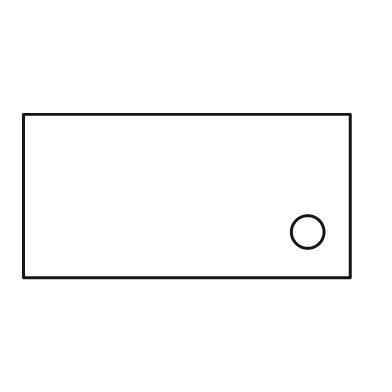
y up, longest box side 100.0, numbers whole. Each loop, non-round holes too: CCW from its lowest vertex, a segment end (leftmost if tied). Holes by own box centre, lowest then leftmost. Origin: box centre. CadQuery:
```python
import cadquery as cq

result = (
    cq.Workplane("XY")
    .moveTo(-50.0, -25.0)
    .lineTo(50.0, -25.0)
    .lineTo(50.0, 25.0)
    .lineTo(-50.0, 25.0)
    .close()
    .moveTo(37.0, -11.0)
    .circle(5.0)
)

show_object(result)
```